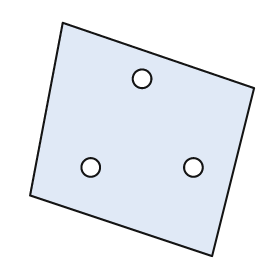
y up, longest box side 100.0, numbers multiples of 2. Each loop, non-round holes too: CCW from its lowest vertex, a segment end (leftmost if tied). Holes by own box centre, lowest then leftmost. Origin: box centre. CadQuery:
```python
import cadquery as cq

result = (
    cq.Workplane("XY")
    .moveTo(30.0, -50.0)
    .lineTo(48.0, 22.0)
    .lineTo(-34.0, 50.0)
    .lineTo(-48.0, -24.0)
    .close()
    .moveTo(-22.0, -12.0)
    .circle(4.0)
    .moveTo(22.0, -12.0)
    .circle(4.0)
    .moveTo(0.0, 26.0)
    .circle(4.0)
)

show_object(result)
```